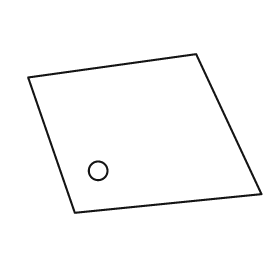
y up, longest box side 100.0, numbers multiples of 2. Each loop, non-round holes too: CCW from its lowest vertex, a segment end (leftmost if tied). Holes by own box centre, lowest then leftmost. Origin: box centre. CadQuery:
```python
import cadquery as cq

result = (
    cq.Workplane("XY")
    .moveTo(-30.0, -34.0)
    .lineTo(50.0, -26.0)
    .lineTo(22.0, 34.0)
    .lineTo(-50.0, 24.0)
    .close()
    .moveTo(-20.0, -16.0)
    .circle(4.0)
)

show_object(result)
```